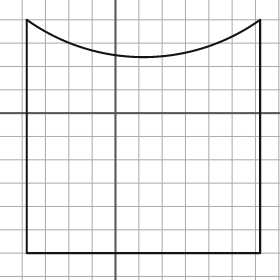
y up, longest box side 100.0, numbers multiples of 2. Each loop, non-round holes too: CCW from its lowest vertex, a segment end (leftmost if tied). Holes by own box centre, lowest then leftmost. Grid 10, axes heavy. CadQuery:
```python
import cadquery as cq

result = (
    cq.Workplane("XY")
    .moveTo(-38.0, -60.0)
    .lineTo(62.0, -60.0)
    .lineTo(62.0, 40.0)
    .threePointArc((12.0, 24.0), (-38.0, 40.0))
    .close()
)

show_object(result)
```